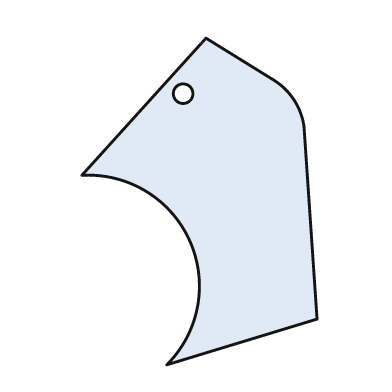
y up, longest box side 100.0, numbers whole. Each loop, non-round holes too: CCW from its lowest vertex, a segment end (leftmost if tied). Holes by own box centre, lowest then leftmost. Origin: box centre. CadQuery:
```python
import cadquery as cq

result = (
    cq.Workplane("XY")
    .moveTo(-10.0, -50.0)
    .lineTo(36.0, -36.0)
    .lineTo(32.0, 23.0)
    .threePointArc((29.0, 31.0), (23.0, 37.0))
    .lineTo(2.0, 50.0)
    .lineTo(-36.0, 8.0)
    .threePointArc((-3.0, -12.0), (-10.0, -50.0))
    .close()
    .moveTo(-5.0, 33.0)
    .circle(3.0)
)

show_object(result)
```